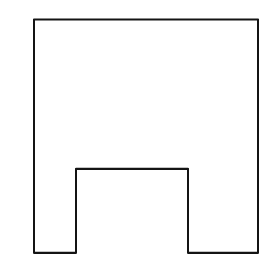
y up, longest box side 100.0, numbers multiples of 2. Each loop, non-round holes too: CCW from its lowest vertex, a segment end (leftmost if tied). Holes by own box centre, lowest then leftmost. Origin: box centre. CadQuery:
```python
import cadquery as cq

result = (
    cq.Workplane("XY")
    .moveTo(-48.0, -50.0)
    .lineTo(-30.0, -50.0)
    .lineTo(-30.0, -14.0)
    .lineTo(18.0, -14.0)
    .lineTo(18.0, -50.0)
    .lineTo(48.0, -50.0)
    .lineTo(48.0, 50.0)
    .lineTo(-48.0, 50.0)
    .close()
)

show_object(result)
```